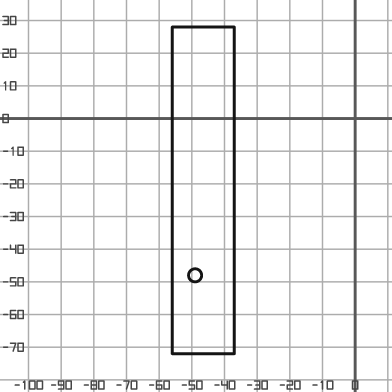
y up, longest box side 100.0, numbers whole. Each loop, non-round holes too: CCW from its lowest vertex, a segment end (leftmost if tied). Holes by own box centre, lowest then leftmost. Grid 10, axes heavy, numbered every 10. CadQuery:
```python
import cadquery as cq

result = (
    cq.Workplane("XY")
    .moveTo(-56.0, -72.0)
    .lineTo(-37.0, -72.0)
    .lineTo(-37.0, 28.0)
    .lineTo(-56.0, 28.0)
    .close()
    .moveTo(-49.0, -48.0)
    .circle(2.0)
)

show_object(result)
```